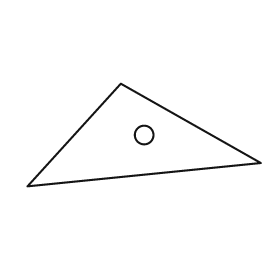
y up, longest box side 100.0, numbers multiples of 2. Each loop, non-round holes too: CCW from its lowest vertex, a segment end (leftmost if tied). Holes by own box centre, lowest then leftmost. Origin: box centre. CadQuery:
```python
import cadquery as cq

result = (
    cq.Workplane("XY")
    .moveTo(-50.0, -22.0)
    .lineTo(50.0, -12.0)
    .lineTo(-10.0, 22.0)
    .close()
    .moveTo(0.0, 0.0)
    .circle(4.0)
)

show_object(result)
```